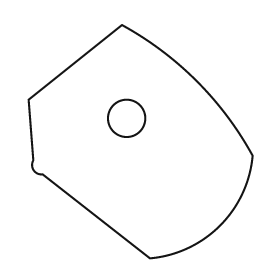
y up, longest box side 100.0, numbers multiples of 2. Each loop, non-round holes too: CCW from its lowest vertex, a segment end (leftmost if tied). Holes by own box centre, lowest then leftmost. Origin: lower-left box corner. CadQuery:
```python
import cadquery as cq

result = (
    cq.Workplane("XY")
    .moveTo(52.0, 0.0)
    .threePointArc((82.0, 14.0), (96.0, 44.0))
    .threePointArc((72.0, 76.0), (40.0, 100.0))
    .lineTo(0.0, 68.0)
    .lineTo(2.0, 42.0)
    .threePointArc((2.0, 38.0), (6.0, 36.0))
    .close()
    .moveTo(42.0, 60.0)
    .circle(8.0)
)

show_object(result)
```